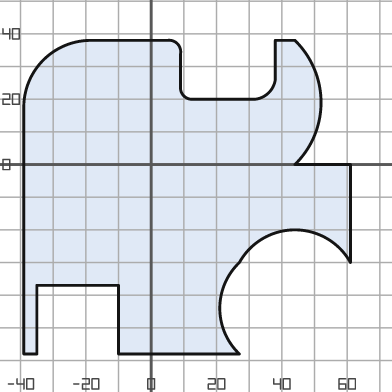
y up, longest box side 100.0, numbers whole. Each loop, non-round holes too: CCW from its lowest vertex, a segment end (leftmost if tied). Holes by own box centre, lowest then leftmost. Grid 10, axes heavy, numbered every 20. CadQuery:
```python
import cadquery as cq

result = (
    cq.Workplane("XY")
    .moveTo(-39.0, -58.0)
    .lineTo(-35.0, -58.0)
    .lineTo(-35.0, -37.0)
    .lineTo(-10.0, -37.0)
    .lineTo(-10.0, -58.0)
    .lineTo(27.0, -58.0)
    .threePointArc((21.0, -44.0), (27.0, -30.0))
    .threePointArc((44.0, -20.0), (61.0, -30.0))
    .lineTo(61.0, 0.0)
    .lineTo(44.0, 0.0)
    .threePointArc((52.0, 19.0), (44.0, 38.0))
    .lineTo(38.0, 38.0)
    .lineTo(38.0, 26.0)
    .threePointArc((36.0, 22.0), (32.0, 20.0))
    .lineTo(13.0, 20.0)
    .threePointArc((10.0, 21.0), (9.0, 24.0))
    .lineTo(9.0, 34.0)
    .threePointArc((8.0, 37.0), (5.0, 38.0))
    .lineTo(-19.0, 38.0)
    .threePointArc((-33.0, 32.0), (-39.0, 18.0))
    .close()
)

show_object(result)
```